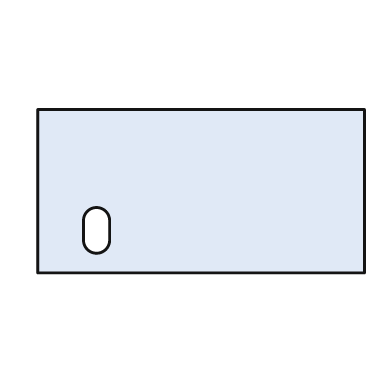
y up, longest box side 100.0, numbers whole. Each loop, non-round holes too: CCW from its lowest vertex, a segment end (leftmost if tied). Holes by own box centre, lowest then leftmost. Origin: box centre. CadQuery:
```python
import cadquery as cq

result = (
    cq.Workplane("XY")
    .moveTo(-50.0, -25.0)
    .lineTo(50.0, -25.0)
    .lineTo(50.0, 25.0)
    .lineTo(-50.0, 25.0)
    .close()
    .moveTo(-36.0, -15.0)
    .threePointArc((-32.0, -19.0), (-28.0, -15.0))
    .lineTo(-28.0, -9.0)
    .threePointArc((-32.0, -5.0), (-36.0, -9.0))
    .close()
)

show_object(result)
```